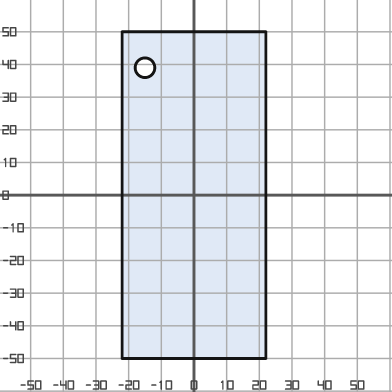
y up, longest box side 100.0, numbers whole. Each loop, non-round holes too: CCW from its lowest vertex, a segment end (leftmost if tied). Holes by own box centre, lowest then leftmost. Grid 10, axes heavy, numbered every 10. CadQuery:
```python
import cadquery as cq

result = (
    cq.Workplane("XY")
    .moveTo(-22.0, -50.0)
    .lineTo(22.0, -50.0)
    .lineTo(22.0, 50.0)
    .lineTo(-22.0, 50.0)
    .close()
    .moveTo(-15.0, 39.0)
    .circle(3.0)
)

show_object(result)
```